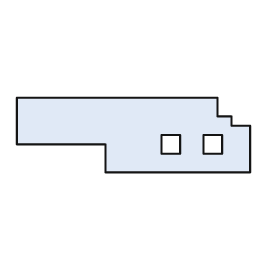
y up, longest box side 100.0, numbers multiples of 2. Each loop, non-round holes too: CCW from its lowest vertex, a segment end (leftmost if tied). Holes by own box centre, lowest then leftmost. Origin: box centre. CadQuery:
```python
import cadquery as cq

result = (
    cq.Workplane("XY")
    .moveTo(-12.0, -16.0)
    .lineTo(50.0, -16.0)
    .lineTo(50.0, 4.0)
    .lineTo(42.0, 4.0)
    .lineTo(42.0, 8.0)
    .lineTo(36.0, 8.0)
    .lineTo(36.0, 16.0)
    .lineTo(-50.0, 16.0)
    .lineTo(-50.0, -4.0)
    .lineTo(-12.0, -4.0)
    .close()
    .moveTo(12.0, -8.0)
    .lineTo(20.0, -8.0)
    .lineTo(20.0, 0.0)
    .lineTo(12.0, 0.0)
    .close()
    .moveTo(30.0, -8.0)
    .lineTo(38.0, -8.0)
    .lineTo(38.0, 0.0)
    .lineTo(30.0, 0.0)
    .close()
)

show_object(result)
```